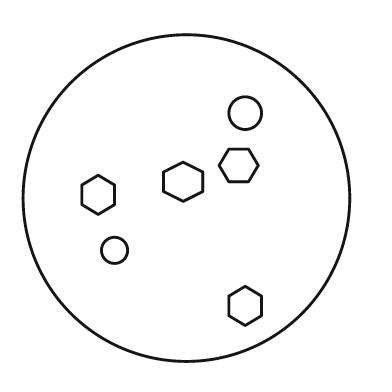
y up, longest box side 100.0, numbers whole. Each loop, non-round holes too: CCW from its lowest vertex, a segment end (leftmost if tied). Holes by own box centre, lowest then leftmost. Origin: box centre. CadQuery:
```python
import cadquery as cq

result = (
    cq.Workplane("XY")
    .moveTo(0.0, 0.0)
    .circle(50.0)
    .moveTo(18.0, -39.0)
    .lineTo(23.0, -36.0)
    .lineTo(23.0, -30.0)
    .lineTo(18.0, -27.0)
    .lineTo(13.0, -30.0)
    .lineTo(13.0, -36.0)
    .close()
    .moveTo(-22.0, -16.0)
    .circle(4.0)
    .moveTo(-27.0, -5.0)
    .lineTo(-22.0, -2.0)
    .lineTo(-22.0, 4.0)
    .lineTo(-27.0, 7.0)
    .lineTo(-32.0, 4.0)
    .lineTo(-32.0, -2.0)
    .close()
    .moveTo(-1.0, -1.0)
    .lineTo(5.0, 2.0)
    .lineTo(5.0, 8.0)
    .lineTo(-1.0, 11.0)
    .lineTo(-7.0, 8.0)
    .lineTo(-7.0, 2.0)
    .close()
    .moveTo(13.0, 5.0)
    .lineTo(19.0, 5.0)
    .lineTo(22.0, 10.0)
    .lineTo(19.0, 15.0)
    .lineTo(13.0, 15.0)
    .lineTo(10.0, 10.0)
    .close()
    .moveTo(18.0, 26.0)
    .circle(5.0)
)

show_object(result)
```